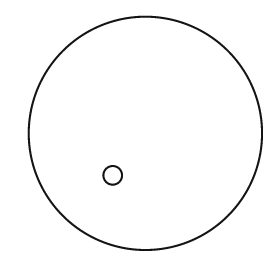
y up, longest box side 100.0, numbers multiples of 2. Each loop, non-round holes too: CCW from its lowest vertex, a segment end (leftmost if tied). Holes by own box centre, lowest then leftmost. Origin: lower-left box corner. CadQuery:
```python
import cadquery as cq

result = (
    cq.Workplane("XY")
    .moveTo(50.0, 50.0)
    .circle(50.0)
    .moveTo(36.0, 32.0)
    .circle(4.0)
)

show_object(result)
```